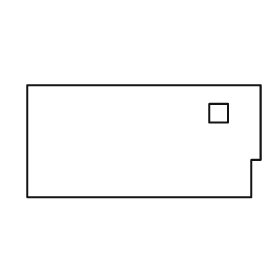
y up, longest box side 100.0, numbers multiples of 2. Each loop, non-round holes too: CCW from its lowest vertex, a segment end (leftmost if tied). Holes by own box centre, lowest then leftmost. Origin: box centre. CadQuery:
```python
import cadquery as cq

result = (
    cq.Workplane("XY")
    .moveTo(-50.0, -24.0)
    .lineTo(46.0, -24.0)
    .lineTo(46.0, -8.0)
    .lineTo(50.0, -8.0)
    .lineTo(50.0, 24.0)
    .lineTo(-50.0, 24.0)
    .close()
    .moveTo(28.0, 8.0)
    .lineTo(36.0, 8.0)
    .lineTo(36.0, 16.0)
    .lineTo(28.0, 16.0)
    .close()
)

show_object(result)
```